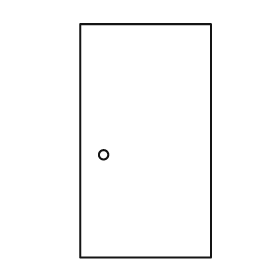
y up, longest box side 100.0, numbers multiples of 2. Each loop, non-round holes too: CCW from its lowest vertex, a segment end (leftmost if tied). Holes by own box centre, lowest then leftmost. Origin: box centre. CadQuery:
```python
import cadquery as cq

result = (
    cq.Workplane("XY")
    .moveTo(-28.0, -50.0)
    .lineTo(28.0, -50.0)
    .lineTo(28.0, 50.0)
    .lineTo(-28.0, 50.0)
    .close()
    .moveTo(-18.0, -6.0)
    .circle(2.0)
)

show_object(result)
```